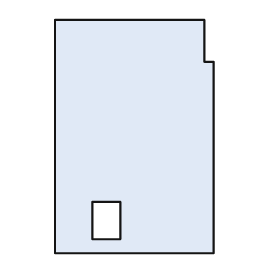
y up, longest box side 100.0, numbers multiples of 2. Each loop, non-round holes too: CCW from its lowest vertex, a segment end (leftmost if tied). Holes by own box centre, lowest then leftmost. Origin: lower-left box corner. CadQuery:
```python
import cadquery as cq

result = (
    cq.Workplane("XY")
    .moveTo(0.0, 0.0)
    .lineTo(68.0, 0.0)
    .lineTo(68.0, 82.0)
    .lineTo(64.0, 82.0)
    .lineTo(64.0, 100.0)
    .lineTo(0.0, 100.0)
    .close()
    .moveTo(16.0, 6.0)
    .lineTo(28.0, 6.0)
    .lineTo(28.0, 22.0)
    .lineTo(16.0, 22.0)
    .close()
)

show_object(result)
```